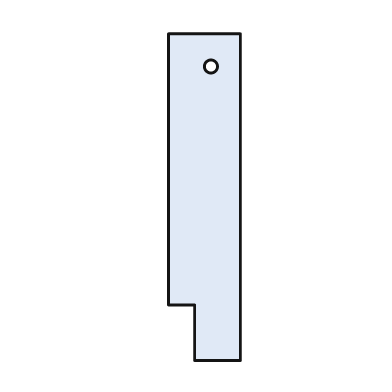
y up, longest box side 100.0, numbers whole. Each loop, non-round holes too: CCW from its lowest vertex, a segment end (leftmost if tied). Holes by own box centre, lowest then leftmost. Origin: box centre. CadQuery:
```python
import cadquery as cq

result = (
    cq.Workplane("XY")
    .moveTo(-3.0, -50.0)
    .lineTo(11.0, -50.0)
    .lineTo(11.0, 50.0)
    .lineTo(-11.0, 50.0)
    .lineTo(-11.0, -33.0)
    .lineTo(-3.0, -33.0)
    .close()
    .moveTo(2.0, 40.0)
    .circle(2.0)
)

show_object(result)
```